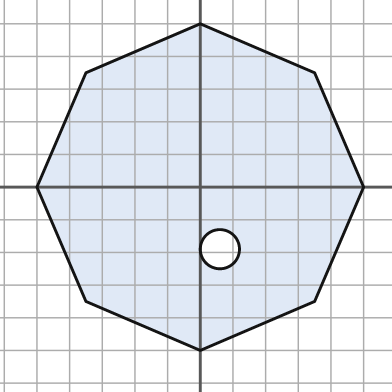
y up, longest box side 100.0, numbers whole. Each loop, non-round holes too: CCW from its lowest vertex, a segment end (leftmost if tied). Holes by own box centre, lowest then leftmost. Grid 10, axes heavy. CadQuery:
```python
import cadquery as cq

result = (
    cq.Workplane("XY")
    .moveTo(0.0, -50.0)
    .lineTo(35.0, -35.0)
    .lineTo(50.0, 0.0)
    .lineTo(35.0, 35.0)
    .lineTo(0.0, 50.0)
    .lineTo(-35.0, 35.0)
    .lineTo(-50.0, 0.0)
    .lineTo(-35.0, -35.0)
    .close()
    .moveTo(6.0, -19.0)
    .circle(6.0)
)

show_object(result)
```